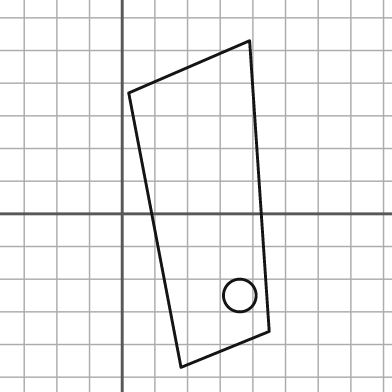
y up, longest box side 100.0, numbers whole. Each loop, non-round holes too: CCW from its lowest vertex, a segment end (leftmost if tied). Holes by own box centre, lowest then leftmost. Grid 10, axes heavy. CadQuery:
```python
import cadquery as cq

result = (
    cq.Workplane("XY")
    .moveTo(18.0, -47.0)
    .lineTo(45.0, -36.0)
    .lineTo(39.0, 53.0)
    .lineTo(2.0, 37.0)
    .close()
    .moveTo(36.0, -25.0)
    .circle(5.0)
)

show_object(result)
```